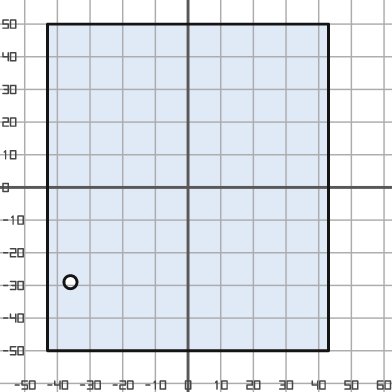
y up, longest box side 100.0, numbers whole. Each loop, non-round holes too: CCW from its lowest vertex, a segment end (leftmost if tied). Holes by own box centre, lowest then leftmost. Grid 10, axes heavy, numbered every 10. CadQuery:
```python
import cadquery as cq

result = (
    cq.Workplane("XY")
    .moveTo(-43.0, -50.0)
    .lineTo(43.0, -50.0)
    .lineTo(43.0, 50.0)
    .lineTo(-43.0, 50.0)
    .close()
    .moveTo(-36.0, -29.0)
    .circle(2.0)
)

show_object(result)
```